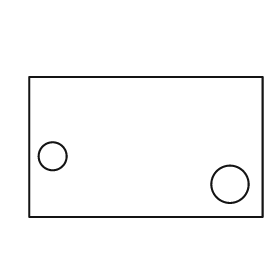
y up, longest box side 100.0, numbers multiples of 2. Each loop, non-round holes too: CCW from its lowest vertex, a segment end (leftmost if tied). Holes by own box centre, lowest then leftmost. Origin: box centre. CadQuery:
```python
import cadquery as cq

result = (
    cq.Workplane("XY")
    .moveTo(-50.0, -30.0)
    .lineTo(50.0, -30.0)
    .lineTo(50.0, 30.0)
    .lineTo(-50.0, 30.0)
    .close()
    .moveTo(36.0, -16.0)
    .circle(8.0)
    .moveTo(-40.0, -4.0)
    .circle(6.0)
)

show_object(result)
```